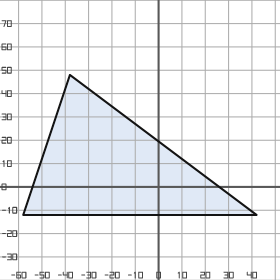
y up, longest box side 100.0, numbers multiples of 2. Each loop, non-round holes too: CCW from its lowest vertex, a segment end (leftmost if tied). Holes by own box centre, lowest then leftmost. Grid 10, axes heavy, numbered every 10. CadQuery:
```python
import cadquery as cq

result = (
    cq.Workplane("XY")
    .moveTo(-58.0, -12.0)
    .lineTo(42.0, -12.0)
    .lineTo(-38.0, 48.0)
    .close()
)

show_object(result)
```